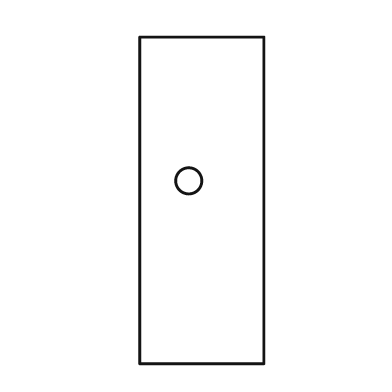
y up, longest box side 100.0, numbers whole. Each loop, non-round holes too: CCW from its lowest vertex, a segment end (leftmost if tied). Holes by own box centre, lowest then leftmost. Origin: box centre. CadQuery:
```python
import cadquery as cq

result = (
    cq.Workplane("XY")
    .moveTo(-19.0, -50.0)
    .lineTo(19.0, -50.0)
    .lineTo(19.0, 50.0)
    .lineTo(-19.0, 50.0)
    .close()
    .moveTo(-4.0, 6.0)
    .circle(4.0)
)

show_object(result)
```